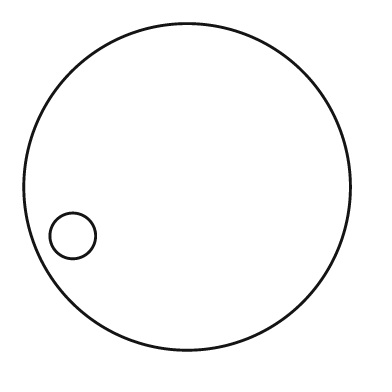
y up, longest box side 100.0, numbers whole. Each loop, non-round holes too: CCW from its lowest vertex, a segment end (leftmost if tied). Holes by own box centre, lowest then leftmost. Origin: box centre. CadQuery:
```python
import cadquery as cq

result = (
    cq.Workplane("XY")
    .moveTo(0.0, 0.0)
    .circle(50.0)
    .moveTo(-35.0, -15.0)
    .circle(7.0)
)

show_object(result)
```